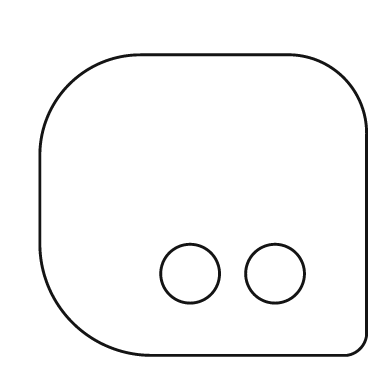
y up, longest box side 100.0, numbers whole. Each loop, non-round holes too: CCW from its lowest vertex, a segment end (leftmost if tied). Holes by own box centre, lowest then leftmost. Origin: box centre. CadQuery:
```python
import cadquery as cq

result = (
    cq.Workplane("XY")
    .moveTo(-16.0, -46.0)
    .lineTo(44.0, -46.0)
    .threePointArc((48.0, -44.0), (50.0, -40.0))
    .lineTo(50.0, 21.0)
    .threePointArc((43.0, 39.0), (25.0, 46.0))
    .lineTo(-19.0, 46.0)
    .threePointArc((-41.0, 37.0), (-50.0, 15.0))
    .lineTo(-50.0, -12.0)
    .threePointArc((-40.0, -36.0), (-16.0, -46.0))
    .close()
    .moveTo(-4.0, -21.0)
    .circle(9.0)
    .moveTo(22.0, -21.0)
    .circle(9.0)
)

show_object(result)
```